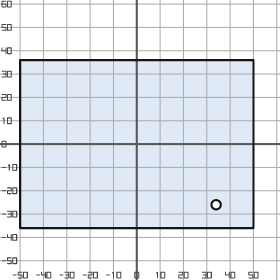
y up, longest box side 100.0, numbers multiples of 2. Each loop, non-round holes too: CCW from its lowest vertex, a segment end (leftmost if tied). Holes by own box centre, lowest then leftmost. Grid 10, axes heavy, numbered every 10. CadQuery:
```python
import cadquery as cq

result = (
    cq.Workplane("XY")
    .moveTo(-50.0, -36.0)
    .lineTo(50.0, -36.0)
    .lineTo(50.0, 36.0)
    .lineTo(-50.0, 36.0)
    .close()
    .moveTo(34.0, -26.0)
    .circle(2.0)
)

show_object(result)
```